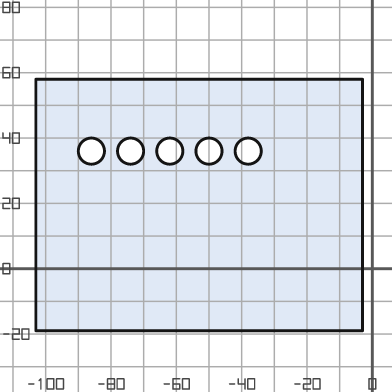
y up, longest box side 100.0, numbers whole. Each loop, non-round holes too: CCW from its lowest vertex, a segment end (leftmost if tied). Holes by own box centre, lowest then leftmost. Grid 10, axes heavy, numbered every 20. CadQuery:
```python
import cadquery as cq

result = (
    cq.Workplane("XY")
    .moveTo(-103.0, -19.0)
    .lineTo(-3.0, -19.0)
    .lineTo(-3.0, 58.0)
    .lineTo(-103.0, 58.0)
    .close()
    .moveTo(-86.0, 36.0)
    .circle(4.0)
    .moveTo(-74.0, 36.0)
    .circle(4.0)
    .moveTo(-62.0, 36.0)
    .circle(4.0)
    .moveTo(-50.0, 36.0)
    .circle(4.0)
    .moveTo(-38.0, 36.0)
    .circle(4.0)
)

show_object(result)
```